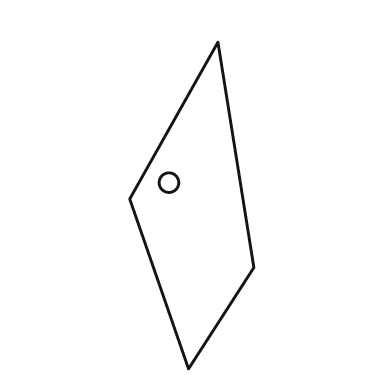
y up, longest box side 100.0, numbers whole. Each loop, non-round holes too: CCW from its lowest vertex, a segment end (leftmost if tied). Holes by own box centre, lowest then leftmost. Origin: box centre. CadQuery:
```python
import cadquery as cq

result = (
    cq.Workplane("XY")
    .moveTo(-1.0, -50.0)
    .lineTo(19.0, -19.0)
    .lineTo(8.0, 50.0)
    .lineTo(-19.0, 2.0)
    .close()
    .moveTo(-7.0, 7.0)
    .circle(3.0)
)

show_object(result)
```